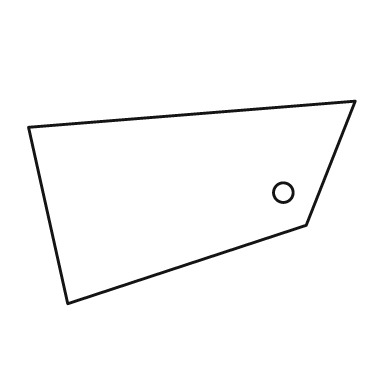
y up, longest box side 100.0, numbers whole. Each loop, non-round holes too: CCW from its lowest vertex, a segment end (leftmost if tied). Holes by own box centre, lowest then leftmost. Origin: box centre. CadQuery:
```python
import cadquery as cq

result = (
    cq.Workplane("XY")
    .moveTo(-38.0, -31.0)
    .lineTo(35.0, -7.0)
    .lineTo(50.0, 31.0)
    .lineTo(-50.0, 23.0)
    .close()
    .moveTo(28.0, 3.0)
    .circle(3.0)
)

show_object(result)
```